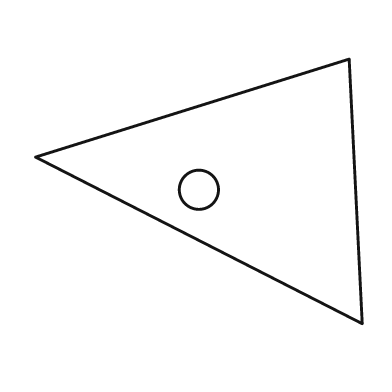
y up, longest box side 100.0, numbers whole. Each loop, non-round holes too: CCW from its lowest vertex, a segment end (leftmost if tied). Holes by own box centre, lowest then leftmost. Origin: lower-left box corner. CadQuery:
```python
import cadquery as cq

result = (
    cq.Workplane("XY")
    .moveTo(100.0, 0.0)
    .lineTo(96.0, 81.0)
    .lineTo(0.0, 51.0)
    .close()
    .moveTo(50.0, 41.0)
    .circle(6.0)
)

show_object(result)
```